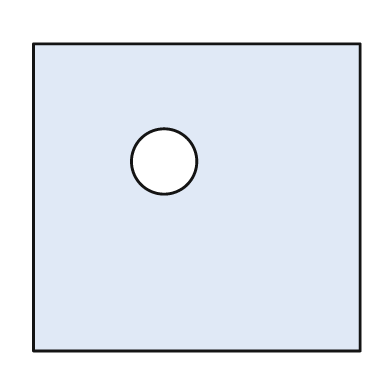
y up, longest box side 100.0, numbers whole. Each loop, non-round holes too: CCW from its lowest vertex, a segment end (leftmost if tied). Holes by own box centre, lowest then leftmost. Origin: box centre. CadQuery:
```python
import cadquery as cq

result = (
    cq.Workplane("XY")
    .moveTo(-50.0, -47.0)
    .lineTo(50.0, -47.0)
    .lineTo(50.0, 47.0)
    .lineTo(-50.0, 47.0)
    .close()
    .moveTo(-10.0, 11.0)
    .circle(10.0)
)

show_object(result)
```